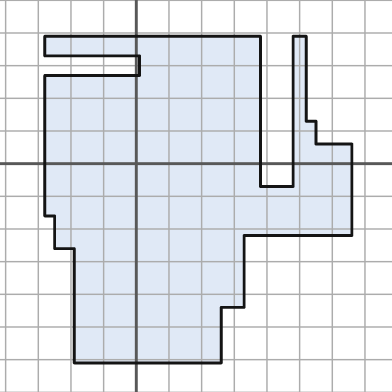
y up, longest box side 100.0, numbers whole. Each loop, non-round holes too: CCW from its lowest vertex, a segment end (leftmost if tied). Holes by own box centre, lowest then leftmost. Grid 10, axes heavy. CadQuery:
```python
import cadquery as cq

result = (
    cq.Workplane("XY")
    .moveTo(-19.0, -61.0)
    .lineTo(26.0, -61.0)
    .lineTo(26.0, -44.0)
    .lineTo(33.0, -44.0)
    .lineTo(33.0, -22.0)
    .lineTo(66.0, -22.0)
    .lineTo(66.0, 6.0)
    .lineTo(55.0, 6.0)
    .lineTo(55.0, 13.0)
    .lineTo(52.0, 13.0)
    .lineTo(52.0, 39.0)
    .lineTo(48.0, 39.0)
    .lineTo(48.0, -7.0)
    .lineTo(38.0, -7.0)
    .lineTo(38.0, 39.0)
    .lineTo(-28.0, 39.0)
    .lineTo(-28.0, 33.0)
    .lineTo(1.0, 33.0)
    .lineTo(1.0, 27.0)
    .lineTo(-28.0, 27.0)
    .lineTo(-28.0, -16.0)
    .lineTo(-25.0, -16.0)
    .lineTo(-25.0, -26.0)
    .lineTo(-19.0, -26.0)
    .close()
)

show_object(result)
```